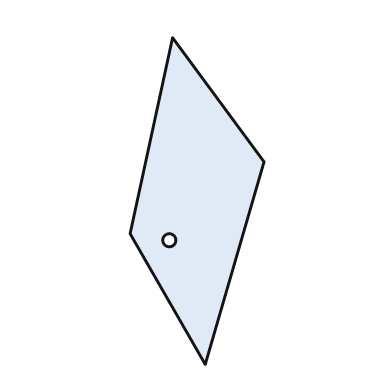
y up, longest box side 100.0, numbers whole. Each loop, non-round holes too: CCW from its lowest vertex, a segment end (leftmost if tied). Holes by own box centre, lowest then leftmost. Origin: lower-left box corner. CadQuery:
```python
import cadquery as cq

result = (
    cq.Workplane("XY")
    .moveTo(23.0, 0.0)
    .lineTo(41.0, 62.0)
    .lineTo(13.0, 100.0)
    .lineTo(0.0, 40.0)
    .close()
    .moveTo(12.0, 38.0)
    .circle(2.0)
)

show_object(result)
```